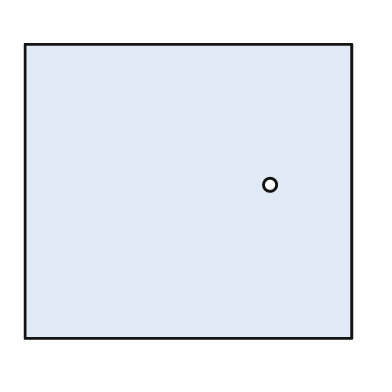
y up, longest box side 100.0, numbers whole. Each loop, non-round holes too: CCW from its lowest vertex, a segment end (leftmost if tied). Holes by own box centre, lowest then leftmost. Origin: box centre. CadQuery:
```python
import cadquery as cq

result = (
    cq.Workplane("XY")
    .moveTo(-50.0, -45.0)
    .lineTo(50.0, -45.0)
    .lineTo(50.0, 45.0)
    .lineTo(-50.0, 45.0)
    .close()
    .moveTo(25.0, 2.0)
    .circle(2.0)
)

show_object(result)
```